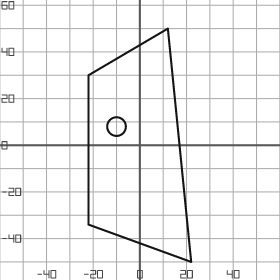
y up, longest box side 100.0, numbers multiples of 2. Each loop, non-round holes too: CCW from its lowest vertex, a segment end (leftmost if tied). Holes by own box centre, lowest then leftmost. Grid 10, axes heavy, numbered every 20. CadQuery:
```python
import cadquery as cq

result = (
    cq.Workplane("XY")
    .moveTo(22.0, -50.0)
    .lineTo(12.0, 50.0)
    .lineTo(-22.0, 30.0)
    .lineTo(-22.0, -34.0)
    .close()
    .moveTo(-10.0, 8.0)
    .circle(4.0)
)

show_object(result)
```